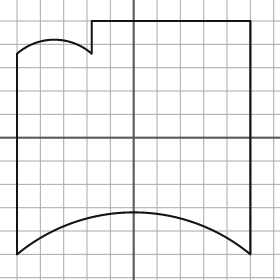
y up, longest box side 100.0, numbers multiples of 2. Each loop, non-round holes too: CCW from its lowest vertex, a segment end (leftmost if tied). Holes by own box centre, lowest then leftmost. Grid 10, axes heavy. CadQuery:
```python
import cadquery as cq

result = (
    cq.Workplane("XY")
    .moveTo(-50.0, -50.0)
    .threePointArc((0.0, -32.0), (50.0, -50.0))
    .lineTo(50.0, 50.0)
    .lineTo(-18.0, 50.0)
    .lineTo(-18.0, 36.0)
    .threePointArc((-34.0, 42.0), (-50.0, 36.0))
    .close()
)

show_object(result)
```